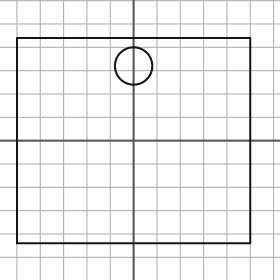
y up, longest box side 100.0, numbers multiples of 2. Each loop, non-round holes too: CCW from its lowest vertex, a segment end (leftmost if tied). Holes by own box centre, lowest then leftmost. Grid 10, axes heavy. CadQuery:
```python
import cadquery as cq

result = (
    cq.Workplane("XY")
    .moveTo(-50.0, -44.0)
    .lineTo(50.0, -44.0)
    .lineTo(50.0, 44.0)
    .lineTo(-50.0, 44.0)
    .close()
    .moveTo(0.0, 32.0)
    .circle(8.0)
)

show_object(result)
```